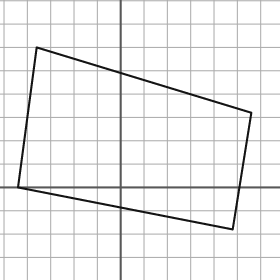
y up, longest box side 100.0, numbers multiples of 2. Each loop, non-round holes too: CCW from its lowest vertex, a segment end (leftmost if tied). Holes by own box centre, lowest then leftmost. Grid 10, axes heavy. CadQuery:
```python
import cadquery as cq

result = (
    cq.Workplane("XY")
    .moveTo(48.0, -18.0)
    .lineTo(56.0, 32.0)
    .lineTo(-36.0, 60.0)
    .lineTo(-44.0, 0.0)
    .close()
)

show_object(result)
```